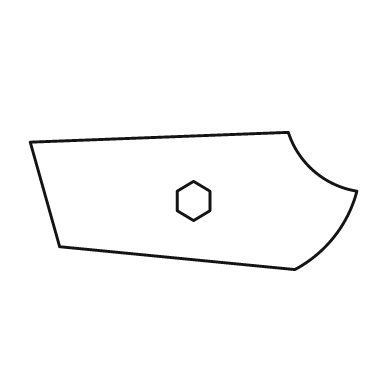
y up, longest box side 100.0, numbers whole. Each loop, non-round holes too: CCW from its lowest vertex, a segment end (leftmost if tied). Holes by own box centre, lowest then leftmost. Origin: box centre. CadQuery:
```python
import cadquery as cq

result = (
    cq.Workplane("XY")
    .moveTo(31.0, -21.0)
    .threePointArc((43.0, -11.0), (50.0, 3.0))
    .threePointArc((37.0, 9.0), (29.0, 21.0))
    .lineTo(-50.0, 18.0)
    .lineTo(-41.0, -14.0)
    .close()
    .moveTo(0.0, -6.0)
    .lineTo(5.0, -3.0)
    .lineTo(5.0, 3.0)
    .lineTo(0.0, 6.0)
    .lineTo(-5.0, 3.0)
    .lineTo(-5.0, -3.0)
    .close()
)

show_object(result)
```